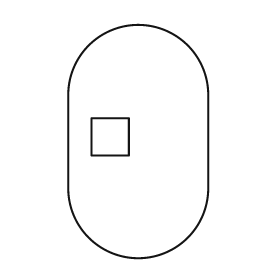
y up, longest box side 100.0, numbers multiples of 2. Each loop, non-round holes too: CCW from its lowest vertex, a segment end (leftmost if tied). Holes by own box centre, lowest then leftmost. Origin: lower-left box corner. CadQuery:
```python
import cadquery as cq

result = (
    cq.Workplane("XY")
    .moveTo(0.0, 30.0)
    .threePointArc((30.0, 0.0), (60.0, 30.0))
    .lineTo(60.0, 70.0)
    .threePointArc((30.0, 100.0), (0.0, 70.0))
    .close()
    .moveTo(10.0, 44.0)
    .lineTo(26.0, 44.0)
    .lineTo(26.0, 60.0)
    .lineTo(10.0, 60.0)
    .close()
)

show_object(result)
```